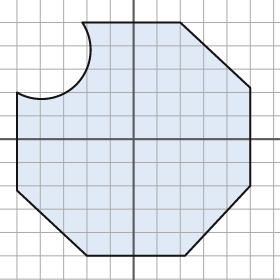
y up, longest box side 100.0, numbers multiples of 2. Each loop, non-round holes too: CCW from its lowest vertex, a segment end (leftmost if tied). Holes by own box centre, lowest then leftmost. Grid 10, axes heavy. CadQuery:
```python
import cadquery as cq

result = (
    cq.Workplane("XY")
    .moveTo(-20.0, -50.0)
    .lineTo(22.0, -50.0)
    .lineTo(50.0, -20.0)
    .lineTo(50.0, 22.0)
    .lineTo(20.0, 50.0)
    .lineTo(-22.0, 50.0)
    .threePointArc((-24.0, 24.0), (-50.0, 20.0))
    .lineTo(-50.0, -22.0)
    .close()
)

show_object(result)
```